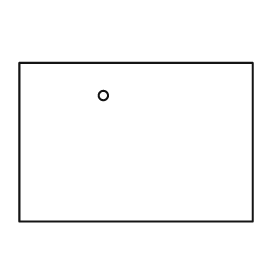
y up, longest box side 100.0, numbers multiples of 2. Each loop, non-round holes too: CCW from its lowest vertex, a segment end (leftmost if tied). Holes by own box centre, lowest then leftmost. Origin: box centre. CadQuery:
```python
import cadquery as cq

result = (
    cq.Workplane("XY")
    .moveTo(-50.0, -34.0)
    .lineTo(50.0, -34.0)
    .lineTo(50.0, 34.0)
    .lineTo(-50.0, 34.0)
    .close()
    .moveTo(-14.0, 20.0)
    .circle(2.0)
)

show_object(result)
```